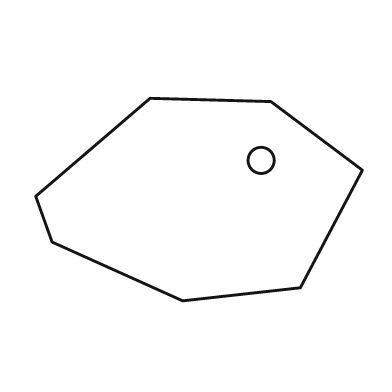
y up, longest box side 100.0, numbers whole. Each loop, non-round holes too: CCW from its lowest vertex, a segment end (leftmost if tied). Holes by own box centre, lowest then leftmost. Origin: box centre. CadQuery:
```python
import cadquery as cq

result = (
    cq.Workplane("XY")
    .moveTo(-5.0, -31.0)
    .lineTo(31.0, -27.0)
    .lineTo(50.0, 9.0)
    .lineTo(22.0, 30.0)
    .lineTo(-15.0, 31.0)
    .lineTo(-50.0, 1.0)
    .lineTo(-45.0, -13.0)
    .close()
    .moveTo(19.0, 12.0)
    .circle(4.0)
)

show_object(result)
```